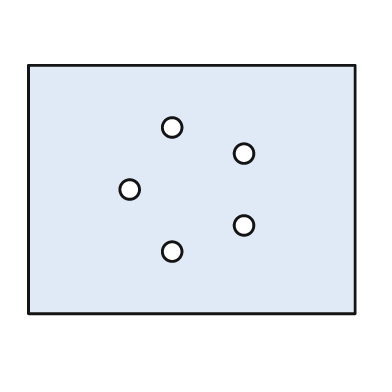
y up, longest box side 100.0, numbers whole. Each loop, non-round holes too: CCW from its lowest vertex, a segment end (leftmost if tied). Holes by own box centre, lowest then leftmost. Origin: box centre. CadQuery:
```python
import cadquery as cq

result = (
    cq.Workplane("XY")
    .moveTo(-50.0, -38.0)
    .lineTo(50.0, -38.0)
    .lineTo(50.0, 38.0)
    .lineTo(-50.0, 38.0)
    .close()
    .moveTo(-6.0, -19.0)
    .circle(3.0)
    .moveTo(16.0, -11.0)
    .circle(3.0)
    .moveTo(-19.0, 0.0)
    .circle(3.0)
    .moveTo(16.0, 11.0)
    .circle(3.0)
    .moveTo(-6.0, 19.0)
    .circle(3.0)
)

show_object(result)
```